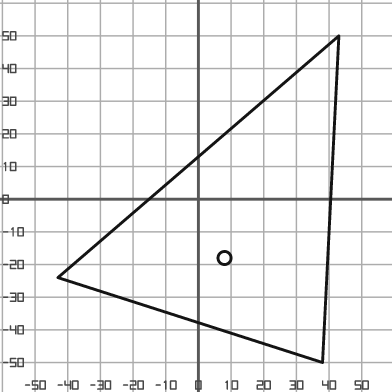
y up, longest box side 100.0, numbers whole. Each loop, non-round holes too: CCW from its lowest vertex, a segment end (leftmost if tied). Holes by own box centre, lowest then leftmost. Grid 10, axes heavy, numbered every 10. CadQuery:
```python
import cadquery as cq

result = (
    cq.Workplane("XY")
    .moveTo(38.0, -50.0)
    .lineTo(43.0, 50.0)
    .lineTo(-43.0, -24.0)
    .close()
    .moveTo(8.0, -18.0)
    .circle(2.0)
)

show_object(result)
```